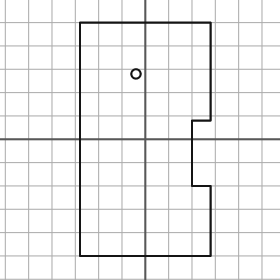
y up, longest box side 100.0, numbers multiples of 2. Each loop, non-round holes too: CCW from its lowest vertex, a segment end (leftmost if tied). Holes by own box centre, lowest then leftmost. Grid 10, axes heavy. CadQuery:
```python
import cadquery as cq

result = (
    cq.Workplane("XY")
    .moveTo(-28.0, -50.0)
    .lineTo(28.0, -50.0)
    .lineTo(28.0, -20.0)
    .lineTo(20.0, -20.0)
    .lineTo(20.0, 8.0)
    .lineTo(28.0, 8.0)
    .lineTo(28.0, 50.0)
    .lineTo(-28.0, 50.0)
    .close()
    .moveTo(-4.0, 28.0)
    .circle(2.0)
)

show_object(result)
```